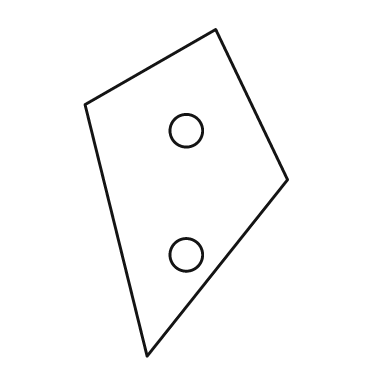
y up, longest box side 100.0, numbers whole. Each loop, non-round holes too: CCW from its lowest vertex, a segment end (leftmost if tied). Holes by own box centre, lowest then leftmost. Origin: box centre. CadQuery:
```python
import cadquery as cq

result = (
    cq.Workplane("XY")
    .moveTo(-12.0, -50.0)
    .lineTo(31.0, 4.0)
    .lineTo(9.0, 50.0)
    .lineTo(-31.0, 27.0)
    .close()
    .moveTo(0.0, -19.0)
    .circle(5.0)
    .moveTo(0.0, 19.0)
    .circle(5.0)
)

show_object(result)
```